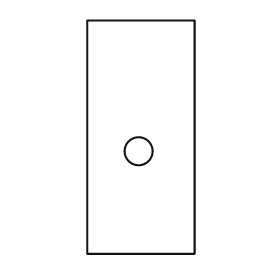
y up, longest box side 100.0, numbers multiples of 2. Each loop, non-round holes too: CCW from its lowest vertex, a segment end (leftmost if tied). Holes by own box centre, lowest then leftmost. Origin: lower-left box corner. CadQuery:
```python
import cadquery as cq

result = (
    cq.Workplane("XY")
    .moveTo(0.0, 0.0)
    .lineTo(46.0, 0.0)
    .lineTo(46.0, 100.0)
    .lineTo(0.0, 100.0)
    .close()
    .moveTo(22.0, 44.0)
    .circle(6.0)
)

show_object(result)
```